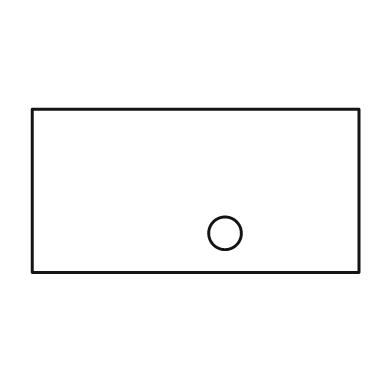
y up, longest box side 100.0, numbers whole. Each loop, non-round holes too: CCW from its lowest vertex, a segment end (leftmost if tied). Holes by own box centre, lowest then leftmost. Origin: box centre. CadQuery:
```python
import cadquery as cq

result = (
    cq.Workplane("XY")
    .moveTo(-50.0, -25.0)
    .lineTo(50.0, -25.0)
    .lineTo(50.0, 25.0)
    .lineTo(-50.0, 25.0)
    .close()
    .moveTo(9.0, -13.0)
    .circle(5.0)
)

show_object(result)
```